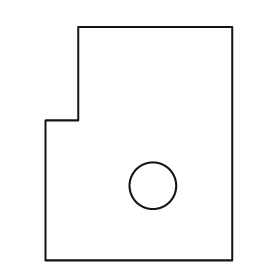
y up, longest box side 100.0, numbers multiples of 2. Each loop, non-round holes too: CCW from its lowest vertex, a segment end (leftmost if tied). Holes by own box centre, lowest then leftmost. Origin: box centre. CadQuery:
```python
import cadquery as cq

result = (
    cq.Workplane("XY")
    .moveTo(-40.0, -50.0)
    .lineTo(40.0, -50.0)
    .lineTo(40.0, 50.0)
    .lineTo(-26.0, 50.0)
    .lineTo(-26.0, 10.0)
    .lineTo(-40.0, 10.0)
    .close()
    .moveTo(6.0, -18.0)
    .circle(10.0)
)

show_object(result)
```